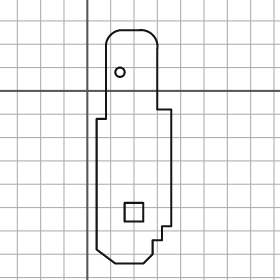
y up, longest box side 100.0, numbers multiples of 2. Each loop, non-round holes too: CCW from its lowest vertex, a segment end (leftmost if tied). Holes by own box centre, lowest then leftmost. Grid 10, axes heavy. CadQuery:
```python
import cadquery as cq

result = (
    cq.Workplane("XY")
    .moveTo(12.0, -74.0)
    .lineTo(24.0, -74.0)
    .lineTo(28.0, -70.0)
    .lineTo(28.0, -64.0)
    .lineTo(32.0, -64.0)
    .lineTo(32.0, -58.0)
    .lineTo(36.0, -58.0)
    .lineTo(36.0, -8.0)
    .lineTo(30.0, -8.0)
    .lineTo(30.0, 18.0)
    .threePointArc((28.0, 24.0), (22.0, 26.0))
    .lineTo(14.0, 26.0)
    .threePointArc((10.0, 24.0), (8.0, 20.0))
    .lineTo(8.0, -12.0)
    .lineTo(4.0, -12.0)
    .lineTo(4.0, -68.0)
    .close()
    .moveTo(16.0, -56.0)
    .lineTo(24.0, -56.0)
    .lineTo(24.0, -48.0)
    .lineTo(16.0, -48.0)
    .close()
    .moveTo(14.0, 8.0)
    .circle(2.0)
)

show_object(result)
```